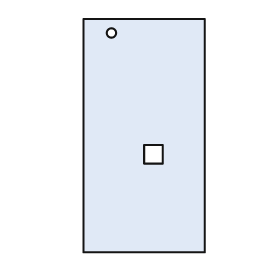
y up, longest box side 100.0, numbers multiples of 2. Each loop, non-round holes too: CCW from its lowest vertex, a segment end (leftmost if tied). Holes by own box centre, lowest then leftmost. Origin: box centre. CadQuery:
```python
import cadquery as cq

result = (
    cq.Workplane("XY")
    .moveTo(-26.0, -50.0)
    .lineTo(26.0, -50.0)
    .lineTo(26.0, 50.0)
    .lineTo(-26.0, 50.0)
    .close()
    .moveTo(0.0, -12.0)
    .lineTo(8.0, -12.0)
    .lineTo(8.0, -4.0)
    .lineTo(0.0, -4.0)
    .close()
    .moveTo(-14.0, 44.0)
    .circle(2.0)
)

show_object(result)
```